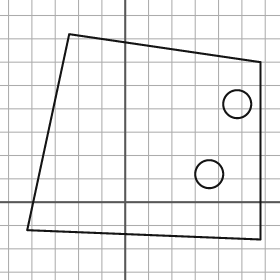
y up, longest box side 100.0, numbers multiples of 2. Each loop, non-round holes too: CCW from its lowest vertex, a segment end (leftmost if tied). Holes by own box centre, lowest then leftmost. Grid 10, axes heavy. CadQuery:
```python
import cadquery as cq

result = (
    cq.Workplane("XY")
    .moveTo(58.0, -16.0)
    .lineTo(58.0, 60.0)
    .lineTo(-24.0, 72.0)
    .lineTo(-42.0, -12.0)
    .close()
    .moveTo(36.0, 12.0)
    .circle(6.0)
    .moveTo(48.0, 42.0)
    .circle(6.0)
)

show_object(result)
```